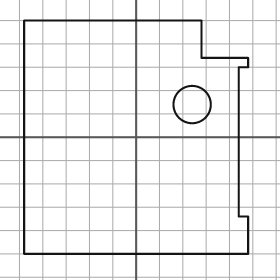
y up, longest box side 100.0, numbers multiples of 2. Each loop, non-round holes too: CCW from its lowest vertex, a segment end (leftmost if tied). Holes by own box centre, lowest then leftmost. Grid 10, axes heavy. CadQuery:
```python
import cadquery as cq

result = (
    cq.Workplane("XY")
    .moveTo(-48.0, -50.0)
    .lineTo(48.0, -50.0)
    .lineTo(48.0, -34.0)
    .lineTo(44.0, -34.0)
    .lineTo(44.0, 30.0)
    .lineTo(48.0, 30.0)
    .lineTo(48.0, 34.0)
    .lineTo(28.0, 34.0)
    .lineTo(28.0, 50.0)
    .lineTo(-48.0, 50.0)
    .close()
    .moveTo(24.0, 14.0)
    .circle(8.0)
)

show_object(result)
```